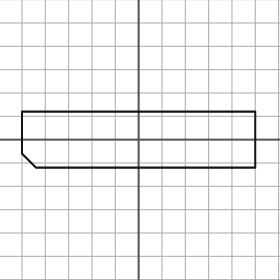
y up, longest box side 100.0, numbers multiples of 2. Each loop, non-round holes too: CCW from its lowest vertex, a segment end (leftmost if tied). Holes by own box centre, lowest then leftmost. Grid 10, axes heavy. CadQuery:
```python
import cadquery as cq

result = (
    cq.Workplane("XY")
    .moveTo(-44.0, -12.0)
    .lineTo(50.0, -12.0)
    .lineTo(50.0, 12.0)
    .lineTo(-50.0, 12.0)
    .lineTo(-50.0, -6.0)
    .close()
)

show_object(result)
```